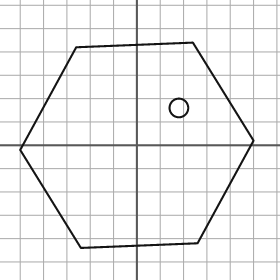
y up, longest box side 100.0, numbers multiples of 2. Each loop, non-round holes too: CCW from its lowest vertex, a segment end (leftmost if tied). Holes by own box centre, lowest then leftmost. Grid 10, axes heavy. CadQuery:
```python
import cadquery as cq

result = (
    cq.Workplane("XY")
    .moveTo(-24.0, -44.0)
    .lineTo(26.0, -42.0)
    .lineTo(50.0, 2.0)
    .lineTo(24.0, 44.0)
    .lineTo(-26.0, 42.0)
    .lineTo(-50.0, -2.0)
    .close()
    .moveTo(18.0, 16.0)
    .circle(4.0)
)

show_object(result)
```